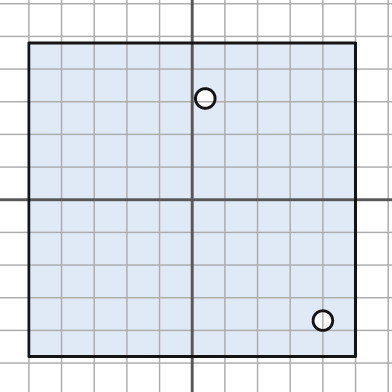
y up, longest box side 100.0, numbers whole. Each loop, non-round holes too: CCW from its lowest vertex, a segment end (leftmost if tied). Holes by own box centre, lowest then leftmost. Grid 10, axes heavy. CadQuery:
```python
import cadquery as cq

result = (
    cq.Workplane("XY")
    .moveTo(-50.0, -48.0)
    .lineTo(50.0, -48.0)
    .lineTo(50.0, 48.0)
    .lineTo(-50.0, 48.0)
    .close()
    .moveTo(40.0, -37.0)
    .circle(3.0)
    .moveTo(4.0, 31.0)
    .circle(3.0)
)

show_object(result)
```